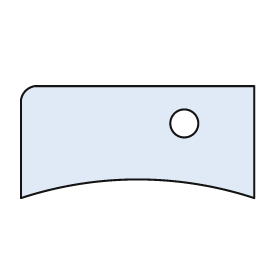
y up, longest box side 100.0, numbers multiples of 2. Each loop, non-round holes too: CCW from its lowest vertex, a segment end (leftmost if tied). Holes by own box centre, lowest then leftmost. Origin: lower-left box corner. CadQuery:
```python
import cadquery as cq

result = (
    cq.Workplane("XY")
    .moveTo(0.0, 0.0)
    .threePointArc((50.0, 8.0), (100.0, 0.0))
    .lineTo(100.0, 48.0)
    .lineTo(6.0, 48.0)
    .threePointArc((2.0, 46.0), (0.0, 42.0))
    .close()
    .moveTo(70.0, 32.0)
    .circle(6.0)
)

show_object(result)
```